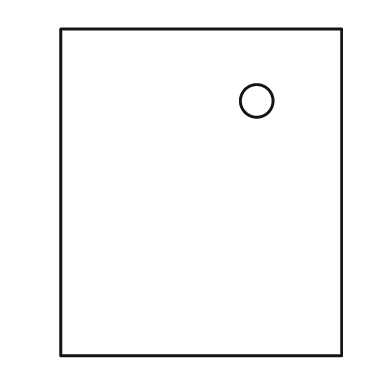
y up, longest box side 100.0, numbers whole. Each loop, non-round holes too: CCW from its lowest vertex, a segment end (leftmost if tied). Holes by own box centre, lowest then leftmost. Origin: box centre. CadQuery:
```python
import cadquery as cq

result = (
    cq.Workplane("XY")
    .moveTo(-43.0, -50.0)
    .lineTo(43.0, -50.0)
    .lineTo(43.0, 50.0)
    .lineTo(-43.0, 50.0)
    .close()
    .moveTo(17.0, 28.0)
    .circle(5.0)
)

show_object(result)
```